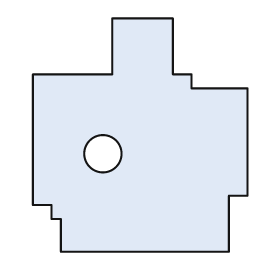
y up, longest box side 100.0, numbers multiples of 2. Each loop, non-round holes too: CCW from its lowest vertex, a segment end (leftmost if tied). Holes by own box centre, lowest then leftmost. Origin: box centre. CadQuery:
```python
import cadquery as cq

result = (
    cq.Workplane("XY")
    .moveTo(-34.0, -50.0)
    .lineTo(38.0, -50.0)
    .lineTo(38.0, -26.0)
    .lineTo(46.0, -26.0)
    .lineTo(46.0, 20.0)
    .lineTo(22.0, 20.0)
    .lineTo(22.0, 26.0)
    .lineTo(14.0, 26.0)
    .lineTo(14.0, 50.0)
    .lineTo(-12.0, 50.0)
    .lineTo(-12.0, 26.0)
    .lineTo(-46.0, 26.0)
    .lineTo(-46.0, -30.0)
    .lineTo(-38.0, -30.0)
    .lineTo(-38.0, -36.0)
    .lineTo(-34.0, -36.0)
    .close()
    .moveTo(-16.0, -8.0)
    .circle(8.0)
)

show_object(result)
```